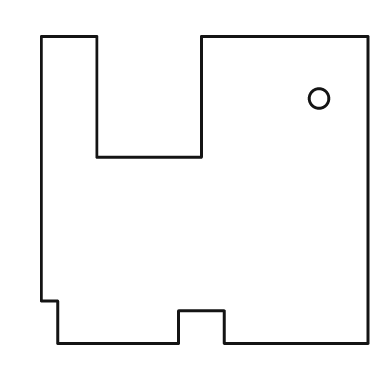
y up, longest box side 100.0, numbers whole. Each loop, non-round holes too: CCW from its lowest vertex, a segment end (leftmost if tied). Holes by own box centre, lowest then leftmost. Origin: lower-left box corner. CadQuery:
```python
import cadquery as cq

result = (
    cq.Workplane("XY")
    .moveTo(5.0, 0.0)
    .lineTo(42.0, 0.0)
    .lineTo(42.0, 10.0)
    .lineTo(56.0, 10.0)
    .lineTo(56.0, 0.0)
    .lineTo(100.0, 0.0)
    .lineTo(100.0, 94.0)
    .lineTo(49.0, 94.0)
    .lineTo(49.0, 57.0)
    .lineTo(17.0, 57.0)
    .lineTo(17.0, 94.0)
    .lineTo(0.0, 94.0)
    .lineTo(0.0, 13.0)
    .lineTo(5.0, 13.0)
    .close()
    .moveTo(85.0, 75.0)
    .circle(3.0)
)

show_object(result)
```